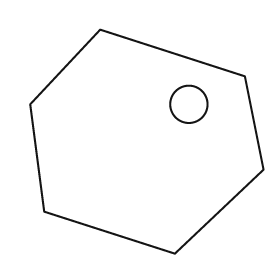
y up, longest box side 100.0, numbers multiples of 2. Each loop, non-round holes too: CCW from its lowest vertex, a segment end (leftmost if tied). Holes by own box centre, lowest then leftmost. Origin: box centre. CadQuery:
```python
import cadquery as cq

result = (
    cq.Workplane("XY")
    .moveTo(12.0, -48.0)
    .lineTo(50.0, -12.0)
    .lineTo(42.0, 28.0)
    .lineTo(-20.0, 48.0)
    .lineTo(-50.0, 16.0)
    .lineTo(-44.0, -30.0)
    .close()
    .moveTo(18.0, 16.0)
    .circle(8.0)
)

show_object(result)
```